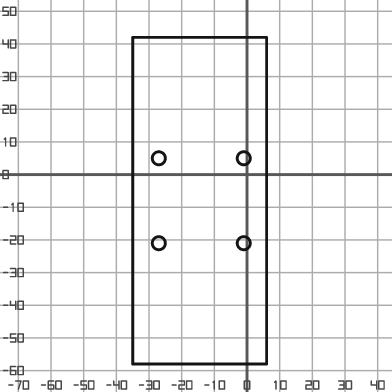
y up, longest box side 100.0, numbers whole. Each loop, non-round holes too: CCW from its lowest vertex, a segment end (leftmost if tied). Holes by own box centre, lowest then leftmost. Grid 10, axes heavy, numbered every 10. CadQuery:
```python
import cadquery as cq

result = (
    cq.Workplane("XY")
    .moveTo(-35.0, -58.0)
    .lineTo(6.0, -58.0)
    .lineTo(6.0, 42.0)
    .lineTo(-35.0, 42.0)
    .close()
    .moveTo(-27.0, -21.0)
    .circle(2.0)
    .moveTo(-1.0, -21.0)
    .circle(2.0)
    .moveTo(-27.0, 5.0)
    .circle(2.0)
    .moveTo(-1.0, 5.0)
    .circle(2.0)
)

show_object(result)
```